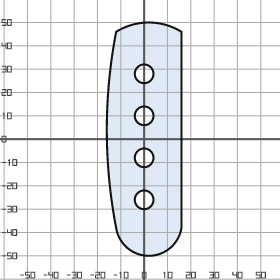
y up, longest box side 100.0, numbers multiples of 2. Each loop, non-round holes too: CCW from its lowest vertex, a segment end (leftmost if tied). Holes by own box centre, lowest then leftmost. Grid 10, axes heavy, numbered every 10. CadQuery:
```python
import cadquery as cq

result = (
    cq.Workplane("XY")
    .moveTo(-12.0, -38.0)
    .threePointArc((2.0, -50.0), (16.0, -38.0))
    .lineTo(16.0, 46.0)
    .threePointArc((2.0, 50.0), (-12.0, 46.0))
    .threePointArc((-16.0, 4.0), (-12.0, -38.0))
    .close()
    .moveTo(0.0, -26.0)
    .circle(4.0)
    .moveTo(0.0, -8.0)
    .circle(4.0)
    .moveTo(0.0, 10.0)
    .circle(4.0)
    .moveTo(0.0, 28.0)
    .circle(4.0)
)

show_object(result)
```